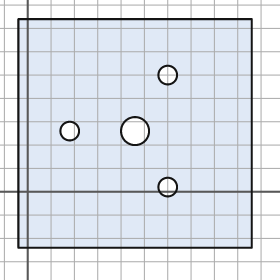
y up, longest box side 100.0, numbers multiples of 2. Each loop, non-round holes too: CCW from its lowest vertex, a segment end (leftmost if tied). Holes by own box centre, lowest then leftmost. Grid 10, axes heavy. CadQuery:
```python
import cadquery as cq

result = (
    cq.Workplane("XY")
    .moveTo(-4.0, -24.0)
    .lineTo(96.0, -24.0)
    .lineTo(96.0, 74.0)
    .lineTo(-4.0, 74.0)
    .close()
    .moveTo(60.0, 2.0)
    .circle(4.0)
    .moveTo(18.0, 26.0)
    .circle(4.0)
    .moveTo(46.0, 26.0)
    .circle(6.0)
    .moveTo(60.0, 50.0)
    .circle(4.0)
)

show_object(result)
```